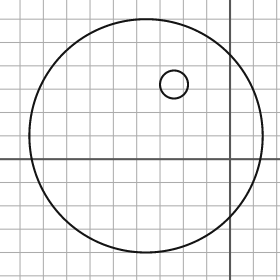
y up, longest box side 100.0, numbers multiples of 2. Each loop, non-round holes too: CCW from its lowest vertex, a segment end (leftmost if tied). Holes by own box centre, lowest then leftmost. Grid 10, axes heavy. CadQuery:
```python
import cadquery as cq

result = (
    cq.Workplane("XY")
    .moveTo(-36.0, 10.0)
    .circle(50.0)
    .moveTo(-24.0, 32.0)
    .circle(6.0)
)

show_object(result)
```